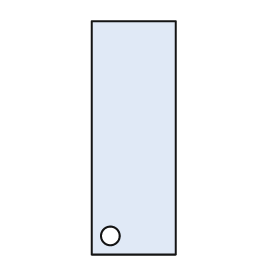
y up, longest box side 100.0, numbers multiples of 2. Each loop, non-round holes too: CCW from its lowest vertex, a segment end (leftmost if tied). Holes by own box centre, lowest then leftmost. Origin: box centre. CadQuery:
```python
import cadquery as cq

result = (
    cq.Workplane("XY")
    .moveTo(-18.0, -50.0)
    .lineTo(18.0, -50.0)
    .lineTo(18.0, 50.0)
    .lineTo(-18.0, 50.0)
    .close()
    .moveTo(-10.0, -42.0)
    .circle(4.0)
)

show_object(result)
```